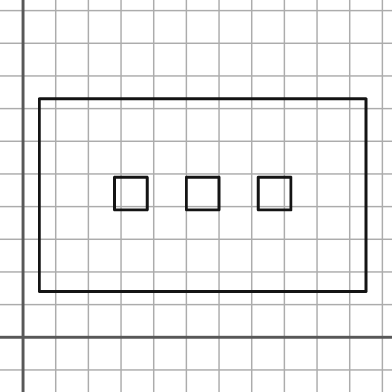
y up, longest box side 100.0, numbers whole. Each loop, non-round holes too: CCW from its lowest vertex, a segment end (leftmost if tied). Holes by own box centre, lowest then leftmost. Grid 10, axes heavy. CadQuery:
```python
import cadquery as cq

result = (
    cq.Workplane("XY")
    .moveTo(5.0, 14.0)
    .lineTo(105.0, 14.0)
    .lineTo(105.0, 73.0)
    .lineTo(5.0, 73.0)
    .close()
    .moveTo(28.0, 39.0)
    .lineTo(38.0, 39.0)
    .lineTo(38.0, 49.0)
    .lineTo(28.0, 49.0)
    .close()
    .moveTo(50.0, 39.0)
    .lineTo(60.0, 39.0)
    .lineTo(60.0, 49.0)
    .lineTo(50.0, 49.0)
    .close()
    .moveTo(72.0, 39.0)
    .lineTo(82.0, 39.0)
    .lineTo(82.0, 49.0)
    .lineTo(72.0, 49.0)
    .close()
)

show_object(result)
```